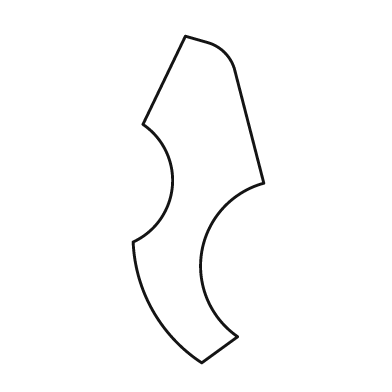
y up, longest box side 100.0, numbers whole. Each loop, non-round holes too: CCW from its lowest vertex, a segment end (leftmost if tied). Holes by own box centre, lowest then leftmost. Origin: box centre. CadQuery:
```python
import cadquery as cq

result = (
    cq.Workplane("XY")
    .moveTo(1.0, -50.0)
    .lineTo(12.0, -42.0)
    .threePointArc((1.0, -16.0), (20.0, 5.0))
    .lineTo(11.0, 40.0)
    .threePointArc((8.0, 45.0), (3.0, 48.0))
    .lineTo(-4.0, 50.0)
    .lineTo(-17.0, 23.0)
    .threePointArc((-8.0, 4.0), (-20.0, -13.0))
    .threePointArc((-14.0, -34.0), (1.0, -50.0))
    .close()
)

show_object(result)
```